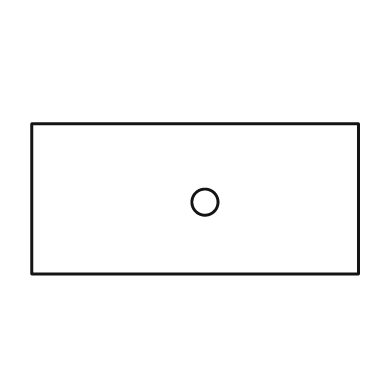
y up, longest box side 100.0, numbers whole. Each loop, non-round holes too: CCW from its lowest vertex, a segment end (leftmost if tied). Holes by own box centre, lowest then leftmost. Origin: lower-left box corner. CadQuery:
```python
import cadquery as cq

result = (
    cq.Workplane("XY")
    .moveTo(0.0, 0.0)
    .lineTo(100.0, 0.0)
    .lineTo(100.0, 46.0)
    .lineTo(0.0, 46.0)
    .close()
    .moveTo(53.0, 22.0)
    .circle(4.0)
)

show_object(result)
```